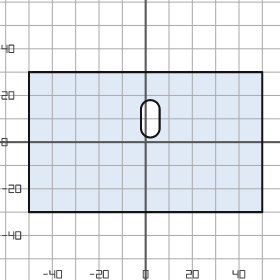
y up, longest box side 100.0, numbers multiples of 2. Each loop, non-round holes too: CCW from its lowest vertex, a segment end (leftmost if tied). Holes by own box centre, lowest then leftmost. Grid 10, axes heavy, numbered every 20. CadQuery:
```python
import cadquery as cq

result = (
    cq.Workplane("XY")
    .moveTo(-50.0, -30.0)
    .lineTo(50.0, -30.0)
    .lineTo(50.0, 30.0)
    .lineTo(-50.0, 30.0)
    .close()
    .moveTo(-2.0, 6.0)
    .threePointArc((2.0, 2.0), (6.0, 6.0))
    .lineTo(6.0, 14.0)
    .threePointArc((2.0, 18.0), (-2.0, 14.0))
    .close()
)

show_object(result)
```